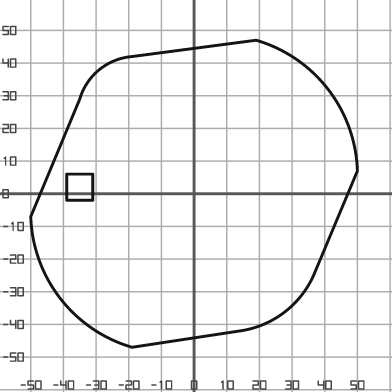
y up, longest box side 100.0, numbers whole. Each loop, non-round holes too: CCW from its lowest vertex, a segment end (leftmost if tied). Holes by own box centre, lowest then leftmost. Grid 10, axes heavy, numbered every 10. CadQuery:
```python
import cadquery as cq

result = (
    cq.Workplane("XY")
    .moveTo(-19.0, -47.0)
    .lineTo(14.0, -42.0)
    .threePointArc((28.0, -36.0), (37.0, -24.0))
    .lineTo(50.0, 7.0)
    .threePointArc((41.0, 32.0), (19.0, 47.0))
    .lineTo(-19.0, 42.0)
    .threePointArc((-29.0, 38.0), (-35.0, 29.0))
    .lineTo(-50.0, -7.0)
    .threePointArc((-41.0, -32.0), (-19.0, -47.0))
    .close()
    .moveTo(-39.0, -2.0)
    .lineTo(-31.0, -2.0)
    .lineTo(-31.0, 6.0)
    .lineTo(-39.0, 6.0)
    .close()
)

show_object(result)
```